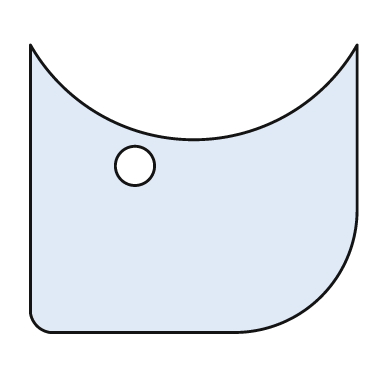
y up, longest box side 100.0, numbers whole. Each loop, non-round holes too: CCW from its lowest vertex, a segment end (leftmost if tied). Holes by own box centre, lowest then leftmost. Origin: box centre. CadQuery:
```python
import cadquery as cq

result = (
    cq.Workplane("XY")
    .moveTo(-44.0, -44.0)
    .lineTo(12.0, -44.0)
    .threePointArc((39.0, -33.0), (50.0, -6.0))
    .lineTo(50.0, 44.0)
    .threePointArc((0.0, 15.0), (-50.0, 44.0))
    .lineTo(-50.0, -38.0)
    .threePointArc((-48.0, -42.0), (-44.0, -44.0))
    .close()
    .moveTo(-18.0, 7.0)
    .circle(6.0)
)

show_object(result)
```